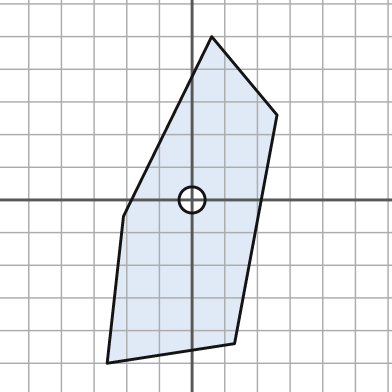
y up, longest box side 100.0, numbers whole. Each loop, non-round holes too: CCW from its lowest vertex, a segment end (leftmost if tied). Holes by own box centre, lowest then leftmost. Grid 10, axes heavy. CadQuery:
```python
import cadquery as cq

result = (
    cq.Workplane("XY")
    .moveTo(-26.0, -50.0)
    .lineTo(13.0, -44.0)
    .lineTo(26.0, 26.0)
    .lineTo(6.0, 50.0)
    .lineTo(-21.0, -5.0)
    .close()
    .moveTo(0.0, 0.0)
    .circle(4.0)
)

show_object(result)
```